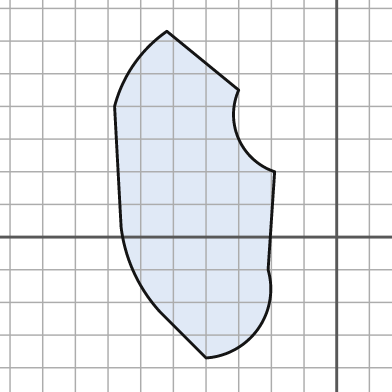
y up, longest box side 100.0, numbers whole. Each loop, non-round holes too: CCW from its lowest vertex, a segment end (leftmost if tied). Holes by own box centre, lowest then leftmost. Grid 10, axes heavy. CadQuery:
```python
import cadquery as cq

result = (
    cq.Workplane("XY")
    .moveTo(-40.0, -37.0)
    .threePointArc((-24.0, -28.0), (-21.0, -10.0))
    .lineTo(-19.0, 20.0)
    .threePointArc((-30.0, 30.0), (-30.0, 45.0))
    .lineTo(-52.0, 63.0)
    .threePointArc((-62.0, 53.0), (-68.0, 40.0))
    .lineTo(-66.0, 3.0)
    .threePointArc((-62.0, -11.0), (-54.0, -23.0))
    .close()
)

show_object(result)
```